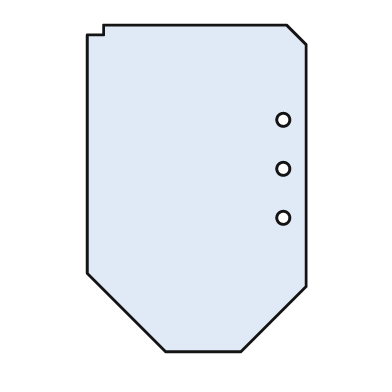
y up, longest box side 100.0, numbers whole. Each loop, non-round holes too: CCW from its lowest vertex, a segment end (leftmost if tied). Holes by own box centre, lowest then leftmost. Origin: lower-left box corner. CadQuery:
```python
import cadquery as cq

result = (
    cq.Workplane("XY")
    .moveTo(24.0, 0.0)
    .lineTo(47.0, 0.0)
    .lineTo(67.0, 20.0)
    .lineTo(67.0, 94.0)
    .lineTo(61.0, 100.0)
    .lineTo(5.0, 100.0)
    .lineTo(5.0, 97.0)
    .lineTo(0.0, 97.0)
    .lineTo(0.0, 24.0)
    .close()
    .moveTo(60.0, 41.0)
    .circle(2.0)
    .moveTo(60.0, 56.0)
    .circle(2.0)
    .moveTo(60.0, 71.0)
    .circle(2.0)
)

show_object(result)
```